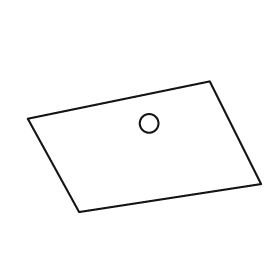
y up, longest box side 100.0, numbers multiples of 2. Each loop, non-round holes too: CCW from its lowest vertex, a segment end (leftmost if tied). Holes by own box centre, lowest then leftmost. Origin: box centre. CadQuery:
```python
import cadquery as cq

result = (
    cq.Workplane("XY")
    .moveTo(-28.0, -28.0)
    .lineTo(50.0, -16.0)
    .lineTo(28.0, 28.0)
    .lineTo(-50.0, 12.0)
    .close()
    .moveTo(2.0, 10.0)
    .circle(4.0)
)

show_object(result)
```